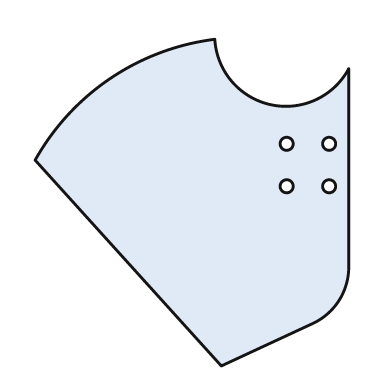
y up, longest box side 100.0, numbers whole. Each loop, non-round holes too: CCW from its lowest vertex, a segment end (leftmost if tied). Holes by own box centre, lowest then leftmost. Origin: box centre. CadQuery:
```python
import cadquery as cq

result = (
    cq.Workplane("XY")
    .moveTo(9.0, -50.0)
    .lineTo(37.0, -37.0)
    .threePointArc((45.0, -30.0), (48.0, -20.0))
    .lineTo(48.0, 41.0)
    .threePointArc((24.0, 30.0), (7.0, 50.0))
    .threePointArc((-25.0, 38.0), (-48.0, 13.0))
    .close()
    .moveTo(29.0, 5.0)
    .circle(2.0)
    .moveTo(42.0, 5.0)
    .circle(2.0)
    .moveTo(29.0, 18.0)
    .circle(2.0)
    .moveTo(42.0, 18.0)
    .circle(2.0)
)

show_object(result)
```